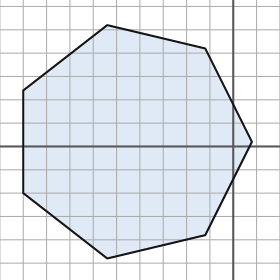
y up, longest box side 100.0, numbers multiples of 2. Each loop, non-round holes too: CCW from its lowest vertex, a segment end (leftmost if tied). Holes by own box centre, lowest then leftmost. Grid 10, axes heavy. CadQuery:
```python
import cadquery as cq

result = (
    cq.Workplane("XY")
    .moveTo(-54.0, -48.0)
    .lineTo(-12.0, -38.0)
    .lineTo(8.0, 2.0)
    .lineTo(-12.0, 42.0)
    .lineTo(-54.0, 52.0)
    .lineTo(-90.0, 24.0)
    .lineTo(-90.0, -20.0)
    .close()
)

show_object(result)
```